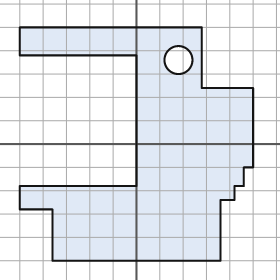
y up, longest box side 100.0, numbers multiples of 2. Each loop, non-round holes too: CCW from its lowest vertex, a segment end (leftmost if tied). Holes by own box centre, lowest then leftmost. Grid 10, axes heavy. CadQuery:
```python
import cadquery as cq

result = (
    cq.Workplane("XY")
    .moveTo(-36.0, -50.0)
    .lineTo(36.0, -50.0)
    .lineTo(36.0, -24.0)
    .lineTo(42.0, -24.0)
    .lineTo(42.0, -18.0)
    .lineTo(46.0, -18.0)
    .lineTo(46.0, -10.0)
    .lineTo(50.0, -10.0)
    .lineTo(50.0, 24.0)
    .lineTo(28.0, 24.0)
    .lineTo(28.0, 50.0)
    .lineTo(-50.0, 50.0)
    .lineTo(-50.0, 38.0)
    .lineTo(0.0, 38.0)
    .lineTo(0.0, -18.0)
    .lineTo(-50.0, -18.0)
    .lineTo(-50.0, -28.0)
    .lineTo(-36.0, -28.0)
    .close()
    .moveTo(18.0, 36.0)
    .circle(6.0)
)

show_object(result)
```